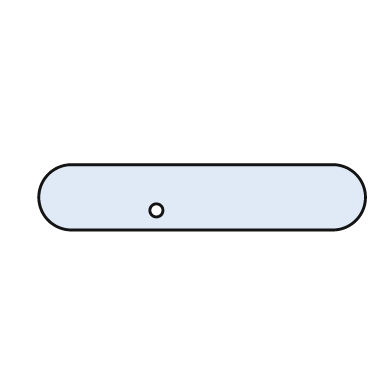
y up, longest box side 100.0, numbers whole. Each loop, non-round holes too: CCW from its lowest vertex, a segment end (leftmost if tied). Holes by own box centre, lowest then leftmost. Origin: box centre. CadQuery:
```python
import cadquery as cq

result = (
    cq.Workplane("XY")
    .moveTo(-40.0, -10.0)
    .lineTo(40.0, -10.0)
    .threePointArc((50.0, 0.0), (40.0, 10.0))
    .lineTo(-40.0, 10.0)
    .threePointArc((-50.0, 0.0), (-40.0, -10.0))
    .close()
    .moveTo(-14.0, -4.0)
    .circle(2.0)
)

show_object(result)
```